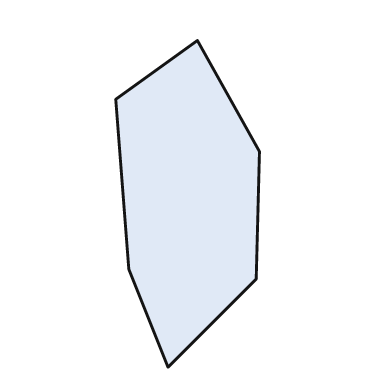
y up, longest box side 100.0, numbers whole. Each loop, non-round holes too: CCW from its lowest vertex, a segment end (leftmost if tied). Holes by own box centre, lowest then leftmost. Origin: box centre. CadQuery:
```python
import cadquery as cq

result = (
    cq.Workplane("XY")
    .moveTo(-6.0, -50.0)
    .lineTo(21.0, -23.0)
    .lineTo(22.0, 16.0)
    .lineTo(3.0, 50.0)
    .lineTo(-22.0, 32.0)
    .lineTo(-18.0, -20.0)
    .close()
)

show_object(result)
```